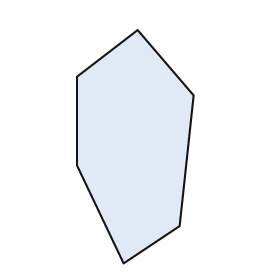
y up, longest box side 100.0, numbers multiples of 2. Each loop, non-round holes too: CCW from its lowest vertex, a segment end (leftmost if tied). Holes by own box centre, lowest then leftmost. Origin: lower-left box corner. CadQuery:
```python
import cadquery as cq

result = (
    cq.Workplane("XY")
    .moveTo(20.0, 0.0)
    .lineTo(44.0, 16.0)
    .lineTo(50.0, 72.0)
    .lineTo(26.0, 100.0)
    .lineTo(0.0, 80.0)
    .lineTo(0.0, 42.0)
    .close()
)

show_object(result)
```